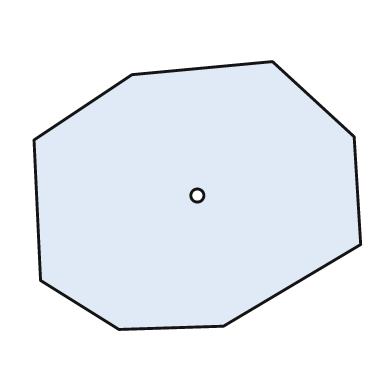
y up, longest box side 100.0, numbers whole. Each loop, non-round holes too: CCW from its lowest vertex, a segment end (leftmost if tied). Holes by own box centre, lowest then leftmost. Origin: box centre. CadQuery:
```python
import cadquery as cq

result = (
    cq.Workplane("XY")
    .moveTo(-24.0, -41.0)
    .lineTo(8.0, -40.0)
    .lineTo(50.0, -15.0)
    .lineTo(48.0, 18.0)
    .lineTo(23.0, 41.0)
    .lineTo(-20.0, 37.0)
    .lineTo(-50.0, 17.0)
    .lineTo(-48.0, -26.0)
    .close()
    .moveTo(0.0, 0.0)
    .circle(2.0)
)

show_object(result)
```